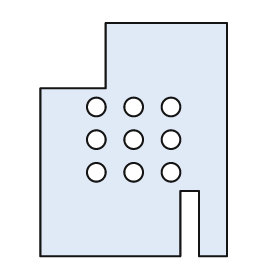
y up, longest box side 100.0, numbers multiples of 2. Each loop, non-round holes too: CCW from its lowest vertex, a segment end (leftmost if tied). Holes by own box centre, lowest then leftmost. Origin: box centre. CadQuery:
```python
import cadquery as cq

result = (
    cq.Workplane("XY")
    .moveTo(-40.0, -50.0)
    .lineTo(20.0, -50.0)
    .lineTo(20.0, -22.0)
    .lineTo(28.0, -22.0)
    .lineTo(28.0, -50.0)
    .lineTo(40.0, -50.0)
    .lineTo(40.0, 50.0)
    .lineTo(-12.0, 50.0)
    .lineTo(-12.0, 22.0)
    .lineTo(-40.0, 22.0)
    .close()
    .moveTo(-16.0, -14.0)
    .circle(4.0)
    .moveTo(0.0, -14.0)
    .circle(4.0)
    .moveTo(16.0, -14.0)
    .circle(4.0)
    .moveTo(-16.0, 0.0)
    .circle(4.0)
    .moveTo(0.0, 0.0)
    .circle(4.0)
    .moveTo(16.0, 0.0)
    .circle(4.0)
    .moveTo(-16.0, 14.0)
    .circle(4.0)
    .moveTo(0.0, 14.0)
    .circle(4.0)
    .moveTo(16.0, 14.0)
    .circle(4.0)
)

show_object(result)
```